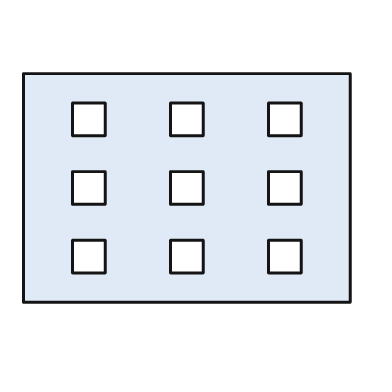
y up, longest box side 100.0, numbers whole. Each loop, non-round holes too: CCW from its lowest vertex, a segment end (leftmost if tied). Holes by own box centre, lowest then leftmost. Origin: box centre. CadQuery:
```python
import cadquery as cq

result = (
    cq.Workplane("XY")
    .moveTo(-50.0, -35.0)
    .lineTo(50.0, -35.0)
    .lineTo(50.0, 35.0)
    .lineTo(-50.0, 35.0)
    .close()
    .moveTo(-35.0, -26.0)
    .lineTo(-25.0, -26.0)
    .lineTo(-25.0, -16.0)
    .lineTo(-35.0, -16.0)
    .close()
    .moveTo(-5.0, -26.0)
    .lineTo(5.0, -26.0)
    .lineTo(5.0, -16.0)
    .lineTo(-5.0, -16.0)
    .close()
    .moveTo(25.0, -26.0)
    .lineTo(35.0, -26.0)
    .lineTo(35.0, -16.0)
    .lineTo(25.0, -16.0)
    .close()
    .moveTo(-35.0, -5.0)
    .lineTo(-25.0, -5.0)
    .lineTo(-25.0, 5.0)
    .lineTo(-35.0, 5.0)
    .close()
    .moveTo(-5.0, -5.0)
    .lineTo(5.0, -5.0)
    .lineTo(5.0, 5.0)
    .lineTo(-5.0, 5.0)
    .close()
    .moveTo(25.0, -5.0)
    .lineTo(35.0, -5.0)
    .lineTo(35.0, 5.0)
    .lineTo(25.0, 5.0)
    .close()
    .moveTo(-35.0, 16.0)
    .lineTo(-25.0, 16.0)
    .lineTo(-25.0, 26.0)
    .lineTo(-35.0, 26.0)
    .close()
    .moveTo(-5.0, 16.0)
    .lineTo(5.0, 16.0)
    .lineTo(5.0, 26.0)
    .lineTo(-5.0, 26.0)
    .close()
    .moveTo(25.0, 16.0)
    .lineTo(35.0, 16.0)
    .lineTo(35.0, 26.0)
    .lineTo(25.0, 26.0)
    .close()
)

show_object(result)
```